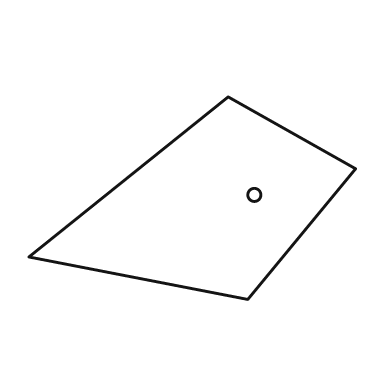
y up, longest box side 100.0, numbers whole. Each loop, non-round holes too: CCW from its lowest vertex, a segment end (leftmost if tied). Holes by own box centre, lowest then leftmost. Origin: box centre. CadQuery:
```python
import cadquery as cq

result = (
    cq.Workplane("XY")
    .moveTo(17.0, -31.0)
    .lineTo(50.0, 9.0)
    .lineTo(11.0, 31.0)
    .lineTo(-50.0, -18.0)
    .close()
    .moveTo(19.0, 1.0)
    .circle(2.0)
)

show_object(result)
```